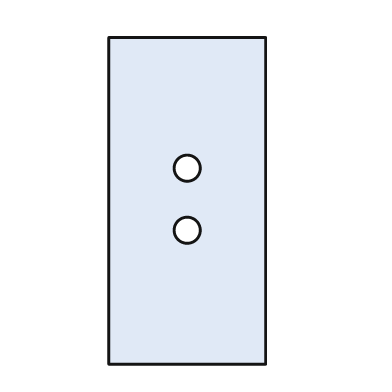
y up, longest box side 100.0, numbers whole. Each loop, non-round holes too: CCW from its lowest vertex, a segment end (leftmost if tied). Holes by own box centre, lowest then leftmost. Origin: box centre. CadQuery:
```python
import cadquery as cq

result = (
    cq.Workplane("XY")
    .moveTo(-24.0, -50.0)
    .lineTo(24.0, -50.0)
    .lineTo(24.0, 50.0)
    .lineTo(-24.0, 50.0)
    .close()
    .moveTo(0.0, -9.0)
    .circle(4.0)
    .moveTo(0.0, 10.0)
    .circle(4.0)
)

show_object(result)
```